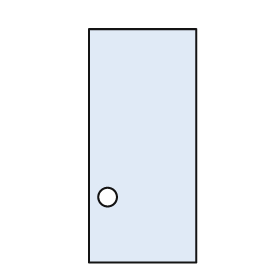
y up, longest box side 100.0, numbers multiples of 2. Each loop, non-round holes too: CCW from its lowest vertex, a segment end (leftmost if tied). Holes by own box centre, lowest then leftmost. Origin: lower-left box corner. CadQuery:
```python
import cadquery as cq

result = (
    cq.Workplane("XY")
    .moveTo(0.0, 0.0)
    .lineTo(46.0, 0.0)
    .lineTo(46.0, 100.0)
    .lineTo(0.0, 100.0)
    .close()
    .moveTo(8.0, 28.0)
    .circle(4.0)
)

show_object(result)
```